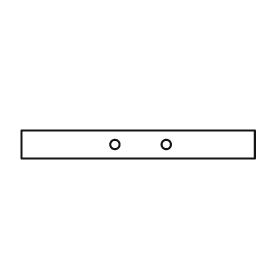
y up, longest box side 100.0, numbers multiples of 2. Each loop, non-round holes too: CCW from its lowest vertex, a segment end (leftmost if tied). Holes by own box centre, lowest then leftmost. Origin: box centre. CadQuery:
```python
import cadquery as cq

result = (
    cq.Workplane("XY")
    .moveTo(-50.0, -6.0)
    .lineTo(50.0, -6.0)
    .lineTo(50.0, 6.0)
    .lineTo(-50.0, 6.0)
    .close()
    .moveTo(-10.0, 0.0)
    .circle(2.0)
    .moveTo(12.0, 0.0)
    .circle(2.0)
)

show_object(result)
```